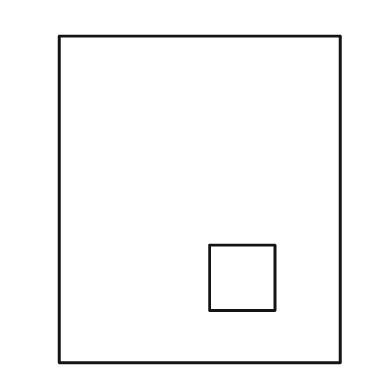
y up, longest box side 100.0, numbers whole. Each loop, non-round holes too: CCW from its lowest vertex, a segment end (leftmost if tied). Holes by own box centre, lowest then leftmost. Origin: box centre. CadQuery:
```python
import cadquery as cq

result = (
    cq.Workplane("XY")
    .moveTo(-43.0, -50.0)
    .lineTo(43.0, -50.0)
    .lineTo(43.0, 50.0)
    .lineTo(-43.0, 50.0)
    .close()
    .moveTo(3.0, -34.0)
    .lineTo(23.0, -34.0)
    .lineTo(23.0, -14.0)
    .lineTo(3.0, -14.0)
    .close()
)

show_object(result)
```